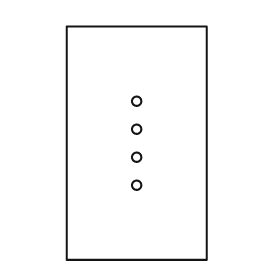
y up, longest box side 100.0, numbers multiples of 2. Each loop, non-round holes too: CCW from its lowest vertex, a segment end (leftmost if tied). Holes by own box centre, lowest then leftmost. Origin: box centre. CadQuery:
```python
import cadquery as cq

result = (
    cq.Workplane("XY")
    .moveTo(-30.0, -50.0)
    .lineTo(30.0, -50.0)
    .lineTo(30.0, 50.0)
    .lineTo(-30.0, 50.0)
    .close()
    .moveTo(0.0, -18.0)
    .circle(2.0)
    .moveTo(0.0, -6.0)
    .circle(2.0)
    .moveTo(0.0, 6.0)
    .circle(2.0)
    .moveTo(0.0, 18.0)
    .circle(2.0)
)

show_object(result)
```